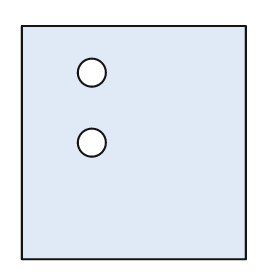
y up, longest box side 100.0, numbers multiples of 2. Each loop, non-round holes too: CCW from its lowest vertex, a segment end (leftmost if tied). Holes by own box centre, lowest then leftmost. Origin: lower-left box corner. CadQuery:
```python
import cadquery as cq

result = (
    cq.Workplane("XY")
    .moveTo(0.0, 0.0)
    .lineTo(96.0, 0.0)
    .lineTo(96.0, 100.0)
    .lineTo(0.0, 100.0)
    .close()
    .moveTo(30.0, 50.0)
    .circle(6.0)
    .moveTo(30.0, 80.0)
    .circle(6.0)
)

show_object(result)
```